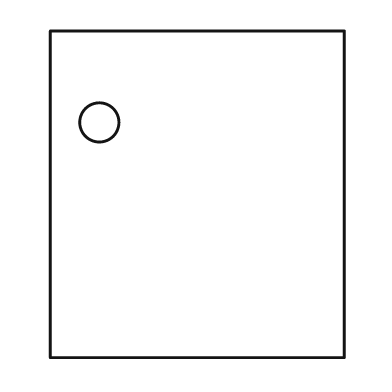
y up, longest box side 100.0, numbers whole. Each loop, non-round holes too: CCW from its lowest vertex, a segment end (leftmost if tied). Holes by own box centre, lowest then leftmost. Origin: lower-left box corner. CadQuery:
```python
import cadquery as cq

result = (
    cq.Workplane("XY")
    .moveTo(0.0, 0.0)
    .lineTo(90.0, 0.0)
    .lineTo(90.0, 100.0)
    .lineTo(0.0, 100.0)
    .close()
    .moveTo(15.0, 72.0)
    .circle(6.0)
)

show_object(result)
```